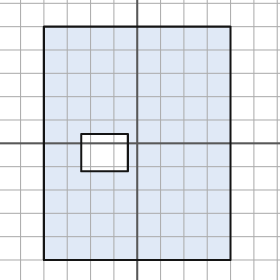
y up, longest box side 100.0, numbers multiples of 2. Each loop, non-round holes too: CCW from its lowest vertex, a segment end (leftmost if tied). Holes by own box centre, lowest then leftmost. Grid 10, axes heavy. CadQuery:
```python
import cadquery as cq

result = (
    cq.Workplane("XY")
    .moveTo(-40.0, -50.0)
    .lineTo(40.0, -50.0)
    .lineTo(40.0, 50.0)
    .lineTo(-40.0, 50.0)
    .close()
    .moveTo(-24.0, -12.0)
    .lineTo(-4.0, -12.0)
    .lineTo(-4.0, 4.0)
    .lineTo(-24.0, 4.0)
    .close()
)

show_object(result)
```